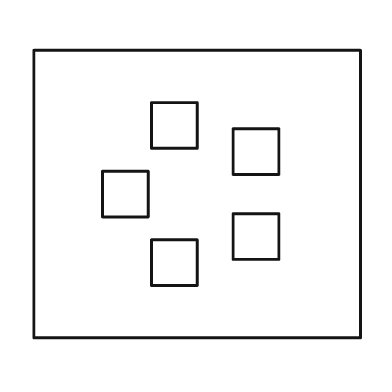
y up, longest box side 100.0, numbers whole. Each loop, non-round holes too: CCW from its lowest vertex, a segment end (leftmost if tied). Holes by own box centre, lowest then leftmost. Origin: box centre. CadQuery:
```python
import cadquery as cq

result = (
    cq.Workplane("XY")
    .moveTo(-50.0, -44.0)
    .lineTo(50.0, -44.0)
    .lineTo(50.0, 44.0)
    .lineTo(-50.0, 44.0)
    .close()
    .moveTo(-14.0, -28.0)
    .lineTo(0.0, -28.0)
    .lineTo(0.0, -14.0)
    .lineTo(-14.0, -14.0)
    .close()
    .moveTo(11.0, -20.0)
    .lineTo(25.0, -20.0)
    .lineTo(25.0, -6.0)
    .lineTo(11.0, -6.0)
    .close()
    .moveTo(-29.0, -7.0)
    .lineTo(-15.0, -7.0)
    .lineTo(-15.0, 7.0)
    .lineTo(-29.0, 7.0)
    .close()
    .moveTo(11.0, 6.0)
    .lineTo(25.0, 6.0)
    .lineTo(25.0, 20.0)
    .lineTo(11.0, 20.0)
    .close()
    .moveTo(-14.0, 14.0)
    .lineTo(0.0, 14.0)
    .lineTo(0.0, 28.0)
    .lineTo(-14.0, 28.0)
    .close()
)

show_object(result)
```